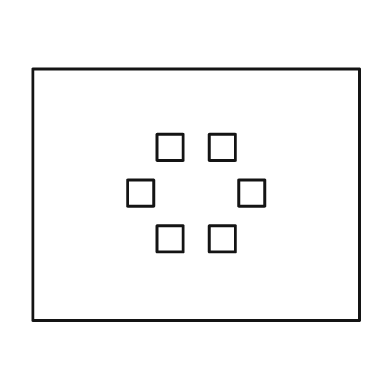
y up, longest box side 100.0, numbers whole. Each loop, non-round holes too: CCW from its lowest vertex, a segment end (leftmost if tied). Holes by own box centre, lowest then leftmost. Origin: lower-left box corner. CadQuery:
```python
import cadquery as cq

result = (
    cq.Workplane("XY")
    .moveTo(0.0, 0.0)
    .lineTo(100.0, 0.0)
    .lineTo(100.0, 77.0)
    .lineTo(0.0, 77.0)
    .close()
    .moveTo(38.0, 21.0)
    .lineTo(46.0, 21.0)
    .lineTo(46.0, 29.0)
    .lineTo(38.0, 29.0)
    .close()
    .moveTo(54.0, 21.0)
    .lineTo(62.0, 21.0)
    .lineTo(62.0, 29.0)
    .lineTo(54.0, 29.0)
    .close()
    .moveTo(29.0, 35.0)
    .lineTo(37.0, 35.0)
    .lineTo(37.0, 43.0)
    .lineTo(29.0, 43.0)
    .close()
    .moveTo(63.0, 35.0)
    .lineTo(71.0, 35.0)
    .lineTo(71.0, 43.0)
    .lineTo(63.0, 43.0)
    .close()
    .moveTo(38.0, 49.0)
    .lineTo(46.0, 49.0)
    .lineTo(46.0, 57.0)
    .lineTo(38.0, 57.0)
    .close()
    .moveTo(54.0, 49.0)
    .lineTo(62.0, 49.0)
    .lineTo(62.0, 57.0)
    .lineTo(54.0, 57.0)
    .close()
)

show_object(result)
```